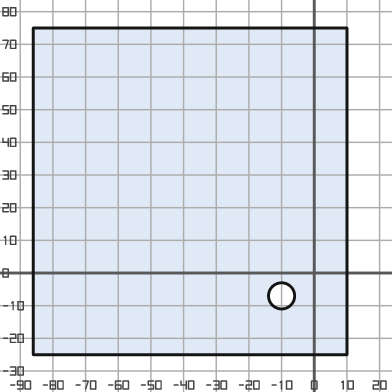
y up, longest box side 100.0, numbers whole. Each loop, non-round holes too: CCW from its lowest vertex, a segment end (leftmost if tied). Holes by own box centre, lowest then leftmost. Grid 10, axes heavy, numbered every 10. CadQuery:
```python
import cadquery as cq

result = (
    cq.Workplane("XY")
    .moveTo(-86.0, -25.0)
    .lineTo(10.0, -25.0)
    .lineTo(10.0, 75.0)
    .lineTo(-86.0, 75.0)
    .close()
    .moveTo(-10.0, -7.0)
    .circle(4.0)
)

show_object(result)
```